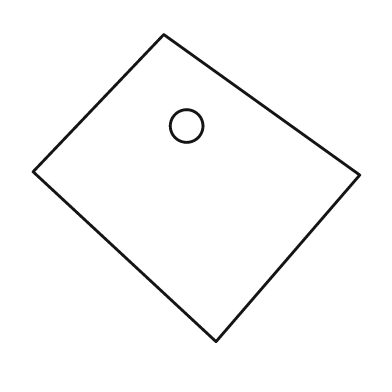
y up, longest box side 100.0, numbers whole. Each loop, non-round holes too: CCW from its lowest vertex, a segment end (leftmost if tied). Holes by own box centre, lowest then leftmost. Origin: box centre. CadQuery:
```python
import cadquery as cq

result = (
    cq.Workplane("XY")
    .moveTo(6.0, -47.0)
    .lineTo(50.0, 4.0)
    .lineTo(-10.0, 47.0)
    .lineTo(-50.0, 5.0)
    .close()
    .moveTo(-3.0, 19.0)
    .circle(5.0)
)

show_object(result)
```